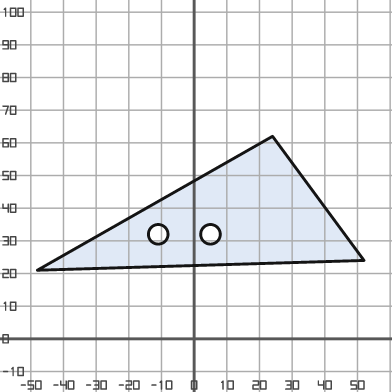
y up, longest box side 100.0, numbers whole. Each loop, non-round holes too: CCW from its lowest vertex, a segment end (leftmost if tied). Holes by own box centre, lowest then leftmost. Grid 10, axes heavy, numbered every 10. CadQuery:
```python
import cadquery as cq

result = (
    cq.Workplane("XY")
    .moveTo(-48.0, 21.0)
    .lineTo(52.0, 24.0)
    .lineTo(24.0, 62.0)
    .close()
    .moveTo(-11.0, 32.0)
    .circle(3.0)
    .moveTo(5.0, 32.0)
    .circle(3.0)
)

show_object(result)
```